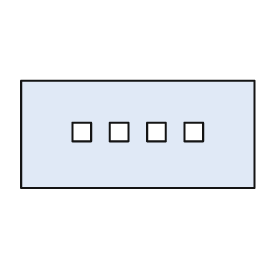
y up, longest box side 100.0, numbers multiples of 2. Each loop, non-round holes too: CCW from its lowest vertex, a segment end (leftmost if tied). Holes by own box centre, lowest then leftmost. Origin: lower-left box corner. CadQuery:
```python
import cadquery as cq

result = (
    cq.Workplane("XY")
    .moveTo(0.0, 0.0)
    .lineTo(100.0, 0.0)
    .lineTo(100.0, 46.0)
    .lineTo(0.0, 46.0)
    .close()
    .moveTo(22.0, 20.0)
    .lineTo(30.0, 20.0)
    .lineTo(30.0, 28.0)
    .lineTo(22.0, 28.0)
    .close()
    .moveTo(38.0, 20.0)
    .lineTo(46.0, 20.0)
    .lineTo(46.0, 28.0)
    .lineTo(38.0, 28.0)
    .close()
    .moveTo(54.0, 20.0)
    .lineTo(62.0, 20.0)
    .lineTo(62.0, 28.0)
    .lineTo(54.0, 28.0)
    .close()
    .moveTo(70.0, 20.0)
    .lineTo(78.0, 20.0)
    .lineTo(78.0, 28.0)
    .lineTo(70.0, 28.0)
    .close()
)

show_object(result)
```